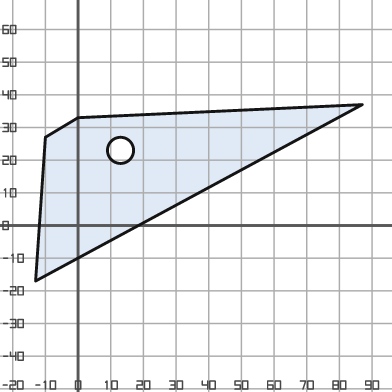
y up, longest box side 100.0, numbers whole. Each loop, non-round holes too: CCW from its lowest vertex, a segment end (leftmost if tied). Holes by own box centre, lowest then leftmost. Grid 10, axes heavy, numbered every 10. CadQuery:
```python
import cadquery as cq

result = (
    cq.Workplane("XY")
    .moveTo(-13.0, -17.0)
    .lineTo(87.0, 37.0)
    .lineTo(0.0, 33.0)
    .lineTo(-10.0, 27.0)
    .close()
    .moveTo(13.0, 23.0)
    .circle(4.0)
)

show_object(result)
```